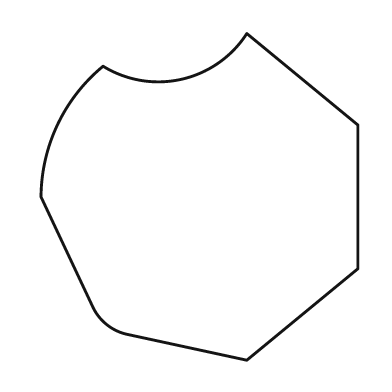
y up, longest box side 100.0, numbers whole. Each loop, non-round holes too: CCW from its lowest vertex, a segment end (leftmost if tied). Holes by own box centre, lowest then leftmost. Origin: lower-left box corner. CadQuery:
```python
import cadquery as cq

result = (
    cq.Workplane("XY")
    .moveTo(63.0, 0.0)
    .lineTo(97.0, 28.0)
    .lineTo(97.0, 72.0)
    .lineTo(63.0, 100.0)
    .threePointArc((43.0, 86.0), (19.0, 90.0))
    .threePointArc((5.0, 72.0), (0.0, 50.0))
    .lineTo(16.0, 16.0)
    .threePointArc((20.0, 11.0), (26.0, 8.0))
    .close()
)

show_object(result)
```